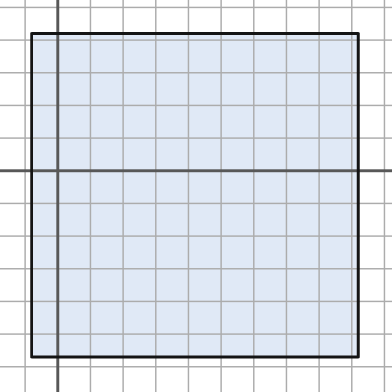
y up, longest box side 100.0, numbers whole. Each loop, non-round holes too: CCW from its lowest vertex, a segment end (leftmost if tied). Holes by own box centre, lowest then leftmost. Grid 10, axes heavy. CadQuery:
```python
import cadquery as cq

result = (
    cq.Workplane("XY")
    .moveTo(-8.0, -57.0)
    .lineTo(92.0, -57.0)
    .lineTo(92.0, 42.0)
    .lineTo(-8.0, 42.0)
    .close()
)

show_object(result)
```